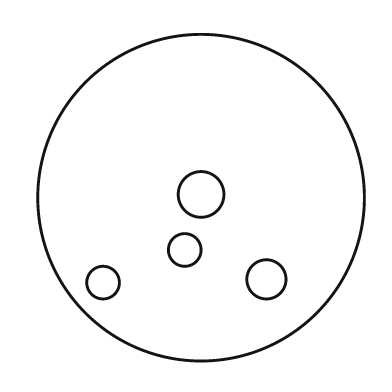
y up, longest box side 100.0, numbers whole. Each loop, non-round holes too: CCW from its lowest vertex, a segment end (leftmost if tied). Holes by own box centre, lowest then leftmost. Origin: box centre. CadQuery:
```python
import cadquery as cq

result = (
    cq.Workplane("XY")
    .moveTo(0.0, 0.0)
    .circle(50.0)
    .moveTo(-30.0, -26.0)
    .circle(5.0)
    .moveTo(20.0, -25.0)
    .circle(6.0)
    .moveTo(-5.0, -16.0)
    .circle(5.0)
    .moveTo(0.0, 1.0)
    .circle(7.0)
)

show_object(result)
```